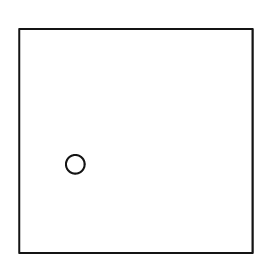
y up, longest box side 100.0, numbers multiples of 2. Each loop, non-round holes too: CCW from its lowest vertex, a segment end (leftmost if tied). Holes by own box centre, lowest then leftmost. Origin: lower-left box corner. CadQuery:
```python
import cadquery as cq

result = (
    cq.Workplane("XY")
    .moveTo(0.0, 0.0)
    .lineTo(100.0, 0.0)
    .lineTo(100.0, 96.0)
    .lineTo(0.0, 96.0)
    .close()
    .moveTo(24.0, 38.0)
    .circle(4.0)
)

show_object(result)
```